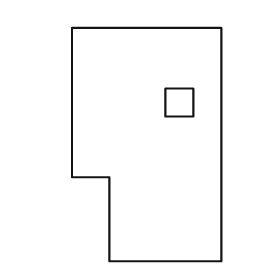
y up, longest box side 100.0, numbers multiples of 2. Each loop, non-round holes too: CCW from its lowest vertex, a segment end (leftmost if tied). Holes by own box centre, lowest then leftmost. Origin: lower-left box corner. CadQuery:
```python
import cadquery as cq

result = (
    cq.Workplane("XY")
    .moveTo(16.0, 0.0)
    .lineTo(64.0, 0.0)
    .lineTo(64.0, 100.0)
    .lineTo(0.0, 100.0)
    .lineTo(0.0, 36.0)
    .lineTo(16.0, 36.0)
    .close()
    .moveTo(40.0, 62.0)
    .lineTo(52.0, 62.0)
    .lineTo(52.0, 74.0)
    .lineTo(40.0, 74.0)
    .close()
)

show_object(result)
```